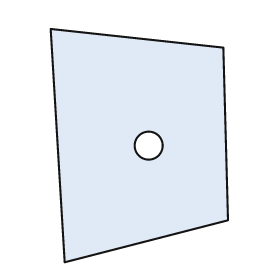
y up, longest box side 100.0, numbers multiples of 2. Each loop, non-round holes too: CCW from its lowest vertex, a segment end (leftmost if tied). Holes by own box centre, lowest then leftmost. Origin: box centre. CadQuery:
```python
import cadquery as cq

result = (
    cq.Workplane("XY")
    .moveTo(-32.0, -50.0)
    .lineTo(38.0, -32.0)
    .lineTo(36.0, 42.0)
    .lineTo(-38.0, 50.0)
    .close()
    .moveTo(4.0, 0.0)
    .circle(6.0)
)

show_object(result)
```